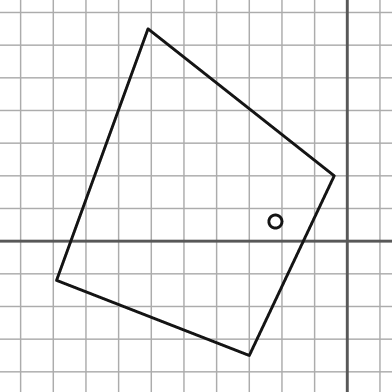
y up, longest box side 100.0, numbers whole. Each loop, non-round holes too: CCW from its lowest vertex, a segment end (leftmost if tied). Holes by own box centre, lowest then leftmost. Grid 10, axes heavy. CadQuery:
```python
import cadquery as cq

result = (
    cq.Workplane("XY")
    .moveTo(-30.0, -35.0)
    .lineTo(-4.0, 20.0)
    .lineTo(-61.0, 65.0)
    .lineTo(-89.0, -12.0)
    .close()
    .moveTo(-22.0, 6.0)
    .circle(2.0)
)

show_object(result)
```